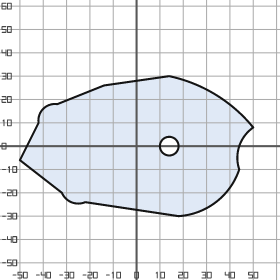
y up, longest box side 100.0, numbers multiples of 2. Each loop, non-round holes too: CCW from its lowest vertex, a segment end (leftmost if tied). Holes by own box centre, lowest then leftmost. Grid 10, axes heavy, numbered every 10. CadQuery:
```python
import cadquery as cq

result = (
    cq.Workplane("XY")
    .moveTo(18.0, -30.0)
    .threePointArc((34.0, -24.0), (44.0, -10.0))
    .threePointArc((44.0, 0.0), (50.0, 8.0))
    .threePointArc((34.0, 22.0), (14.0, 30.0))
    .lineTo(-14.0, 26.0)
    .lineTo(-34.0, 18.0)
    .threePointArc((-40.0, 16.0), (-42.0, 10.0))
    .lineTo(-50.0, -6.0)
    .lineTo(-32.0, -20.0)
    .threePointArc((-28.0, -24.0), (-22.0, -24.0))
    .close()
    .moveTo(14.0, 0.0)
    .circle(4.0)
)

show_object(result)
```